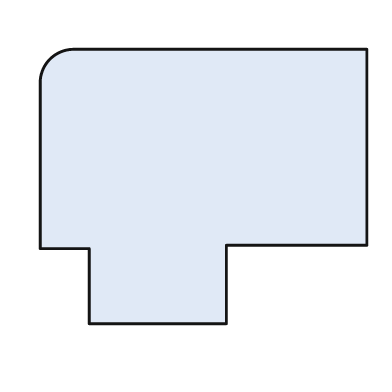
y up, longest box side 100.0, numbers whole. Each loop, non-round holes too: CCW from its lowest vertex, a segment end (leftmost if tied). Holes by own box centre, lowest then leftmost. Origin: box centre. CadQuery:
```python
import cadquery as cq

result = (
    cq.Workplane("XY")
    .moveTo(-35.0, -42.0)
    .lineTo(7.0, -42.0)
    .lineTo(7.0, -18.0)
    .lineTo(50.0, -18.0)
    .lineTo(50.0, 42.0)
    .lineTo(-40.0, 42.0)
    .threePointArc((-47.0, 39.0), (-50.0, 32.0))
    .lineTo(-50.0, -19.0)
    .lineTo(-35.0, -19.0)
    .close()
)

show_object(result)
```